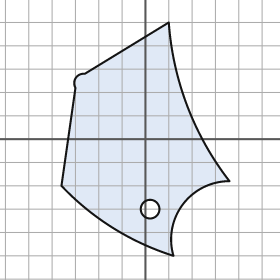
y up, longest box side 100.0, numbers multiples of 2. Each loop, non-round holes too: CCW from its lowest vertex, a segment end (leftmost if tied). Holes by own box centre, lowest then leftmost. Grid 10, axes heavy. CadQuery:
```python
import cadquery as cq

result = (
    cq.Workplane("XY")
    .moveTo(12.0, -50.0)
    .threePointArc((16.0, -28.0), (36.0, -18.0))
    .threePointArc((18.0, 14.0), (10.0, 50.0))
    .lineTo(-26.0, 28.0)
    .threePointArc((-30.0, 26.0), (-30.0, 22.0))
    .lineTo(-36.0, -20.0)
    .threePointArc((-14.0, -38.0), (12.0, -50.0))
    .close()
    .moveTo(2.0, -30.0)
    .circle(4.0)
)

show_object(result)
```